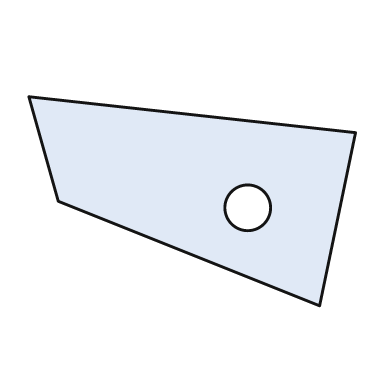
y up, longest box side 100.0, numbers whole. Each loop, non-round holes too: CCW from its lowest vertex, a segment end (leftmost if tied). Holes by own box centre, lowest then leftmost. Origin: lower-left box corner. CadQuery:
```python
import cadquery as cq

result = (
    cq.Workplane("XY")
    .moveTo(89.0, 0.0)
    .lineTo(100.0, 53.0)
    .lineTo(0.0, 64.0)
    .lineTo(9.0, 32.0)
    .close()
    .moveTo(67.0, 30.0)
    .circle(7.0)
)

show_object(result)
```